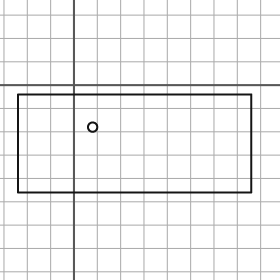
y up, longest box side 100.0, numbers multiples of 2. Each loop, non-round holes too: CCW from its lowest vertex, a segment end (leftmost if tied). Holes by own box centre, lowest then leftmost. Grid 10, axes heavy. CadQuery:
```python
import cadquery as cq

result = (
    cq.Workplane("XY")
    .moveTo(-24.0, -46.0)
    .lineTo(76.0, -46.0)
    .lineTo(76.0, -4.0)
    .lineTo(-24.0, -4.0)
    .close()
    .moveTo(8.0, -18.0)
    .circle(2.0)
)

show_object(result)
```